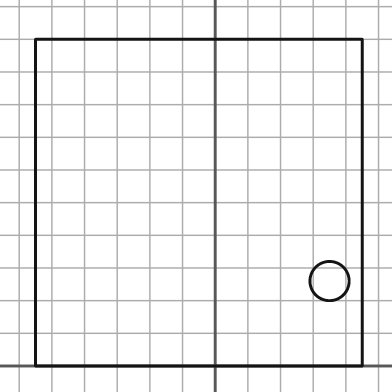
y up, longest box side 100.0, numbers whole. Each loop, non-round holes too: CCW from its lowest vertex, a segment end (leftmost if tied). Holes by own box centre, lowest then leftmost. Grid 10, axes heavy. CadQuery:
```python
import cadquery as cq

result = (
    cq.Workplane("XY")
    .moveTo(-55.0, 0.0)
    .lineTo(45.0, 0.0)
    .lineTo(45.0, 100.0)
    .lineTo(-55.0, 100.0)
    .close()
    .moveTo(35.0, 26.0)
    .circle(6.0)
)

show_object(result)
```